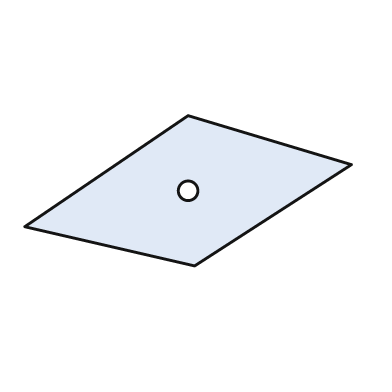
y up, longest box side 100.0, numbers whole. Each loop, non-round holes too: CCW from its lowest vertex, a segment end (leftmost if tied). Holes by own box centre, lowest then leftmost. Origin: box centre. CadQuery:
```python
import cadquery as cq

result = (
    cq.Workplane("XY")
    .moveTo(2.0, -23.0)
    .lineTo(50.0, 8.0)
    .lineTo(0.0, 23.0)
    .lineTo(-50.0, -11.0)
    .close()
    .moveTo(0.0, 0.0)
    .circle(3.0)
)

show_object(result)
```